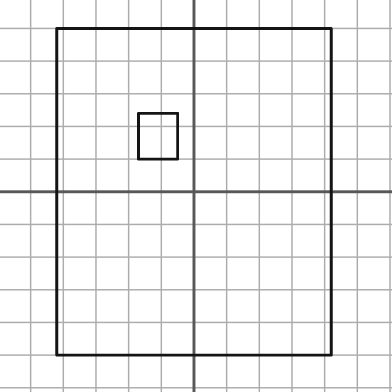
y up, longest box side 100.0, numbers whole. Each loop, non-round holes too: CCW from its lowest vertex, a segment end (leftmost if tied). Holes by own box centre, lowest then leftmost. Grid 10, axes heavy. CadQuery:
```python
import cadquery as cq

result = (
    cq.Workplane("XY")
    .moveTo(-42.0, -50.0)
    .lineTo(42.0, -50.0)
    .lineTo(42.0, 50.0)
    .lineTo(-42.0, 50.0)
    .close()
    .moveTo(-17.0, 10.0)
    .lineTo(-5.0, 10.0)
    .lineTo(-5.0, 24.0)
    .lineTo(-17.0, 24.0)
    .close()
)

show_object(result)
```